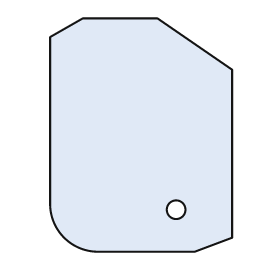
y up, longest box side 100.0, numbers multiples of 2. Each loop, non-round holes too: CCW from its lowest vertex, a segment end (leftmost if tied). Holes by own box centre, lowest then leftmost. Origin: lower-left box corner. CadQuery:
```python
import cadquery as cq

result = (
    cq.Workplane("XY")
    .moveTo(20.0, 0.0)
    .lineTo(62.0, 0.0)
    .lineTo(78.0, 6.0)
    .lineTo(78.0, 78.0)
    .lineTo(46.0, 100.0)
    .lineTo(14.0, 100.0)
    .lineTo(0.0, 92.0)
    .lineTo(0.0, 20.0)
    .threePointArc((6.0, 6.0), (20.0, 0.0))
    .close()
    .moveTo(54.0, 18.0)
    .circle(4.0)
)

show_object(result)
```